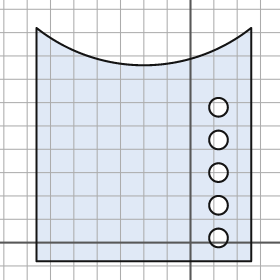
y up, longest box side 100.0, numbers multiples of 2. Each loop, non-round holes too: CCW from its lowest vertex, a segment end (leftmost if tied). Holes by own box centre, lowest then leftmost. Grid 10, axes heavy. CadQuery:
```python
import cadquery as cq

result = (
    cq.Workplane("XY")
    .moveTo(-66.0, -8.0)
    .lineTo(26.0, -8.0)
    .lineTo(26.0, 92.0)
    .threePointArc((-20.0, 76.0), (-66.0, 92.0))
    .close()
    .moveTo(12.0, 2.0)
    .circle(4.0)
    .moveTo(12.0, 16.0)
    .circle(4.0)
    .moveTo(12.0, 30.0)
    .circle(4.0)
    .moveTo(12.0, 44.0)
    .circle(4.0)
    .moveTo(12.0, 58.0)
    .circle(4.0)
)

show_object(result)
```